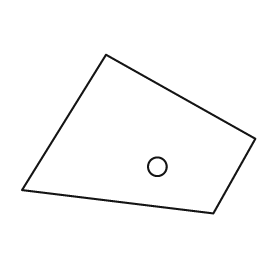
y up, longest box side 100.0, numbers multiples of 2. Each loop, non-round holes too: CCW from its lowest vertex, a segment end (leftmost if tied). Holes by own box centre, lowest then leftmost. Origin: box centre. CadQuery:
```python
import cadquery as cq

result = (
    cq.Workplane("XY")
    .moveTo(32.0, -34.0)
    .lineTo(50.0, -2.0)
    .lineTo(-14.0, 34.0)
    .lineTo(-50.0, -24.0)
    .close()
    .moveTo(8.0, -14.0)
    .circle(4.0)
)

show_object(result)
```